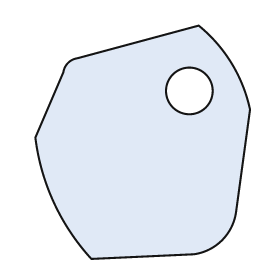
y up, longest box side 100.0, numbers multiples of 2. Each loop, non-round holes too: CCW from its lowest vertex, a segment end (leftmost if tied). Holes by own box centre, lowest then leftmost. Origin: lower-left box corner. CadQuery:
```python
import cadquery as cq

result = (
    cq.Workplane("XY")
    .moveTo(24.0, 0.0)
    .lineTo(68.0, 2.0)
    .threePointArc((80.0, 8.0), (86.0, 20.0))
    .lineTo(92.0, 64.0)
    .threePointArc((84.0, 84.0), (70.0, 100.0))
    .lineTo(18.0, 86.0)
    .threePointArc((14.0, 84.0), (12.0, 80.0))
    .lineTo(0.0, 52.0)
    .threePointArc((8.0, 24.0), (24.0, 0.0))
    .close()
    .moveTo(66.0, 72.0)
    .circle(10.0)
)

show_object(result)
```